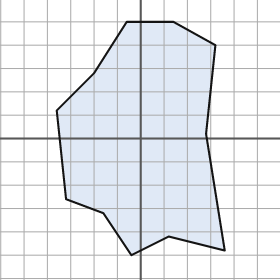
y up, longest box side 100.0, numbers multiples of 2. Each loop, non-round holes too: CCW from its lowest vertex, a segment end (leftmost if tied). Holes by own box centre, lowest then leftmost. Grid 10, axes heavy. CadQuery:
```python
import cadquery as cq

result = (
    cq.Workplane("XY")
    .moveTo(-4.0, -50.0)
    .lineTo(12.0, -42.0)
    .lineTo(36.0, -48.0)
    .lineTo(28.0, 2.0)
    .lineTo(32.0, 40.0)
    .lineTo(14.0, 50.0)
    .lineTo(-6.0, 50.0)
    .lineTo(-20.0, 28.0)
    .lineTo(-36.0, 12.0)
    .lineTo(-32.0, -26.0)
    .lineTo(-16.0, -32.0)
    .close()
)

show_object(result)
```